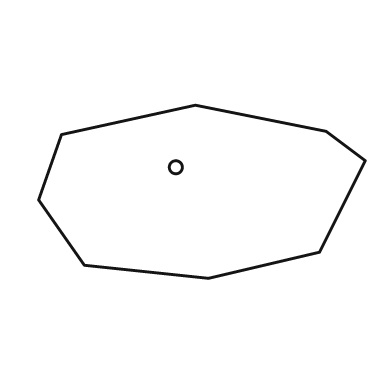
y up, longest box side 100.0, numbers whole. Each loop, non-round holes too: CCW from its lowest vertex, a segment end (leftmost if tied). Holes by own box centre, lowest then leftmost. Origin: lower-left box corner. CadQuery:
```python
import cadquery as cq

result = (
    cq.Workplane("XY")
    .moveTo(52.0, 0.0)
    .lineTo(86.0, 8.0)
    .lineTo(100.0, 36.0)
    .lineTo(88.0, 45.0)
    .lineTo(48.0, 53.0)
    .lineTo(7.0, 44.0)
    .lineTo(0.0, 24.0)
    .lineTo(14.0, 4.0)
    .close()
    .moveTo(42.0, 34.0)
    .circle(2.0)
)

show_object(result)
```